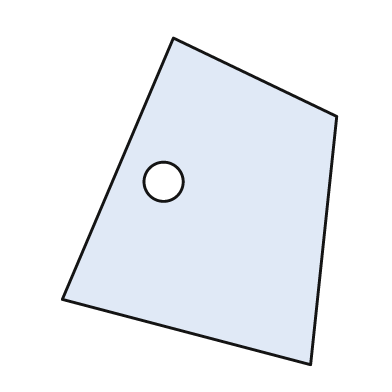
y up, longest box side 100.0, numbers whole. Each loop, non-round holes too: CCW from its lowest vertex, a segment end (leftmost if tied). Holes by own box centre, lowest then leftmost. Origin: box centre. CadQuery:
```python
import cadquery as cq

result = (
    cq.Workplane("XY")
    .moveTo(34.0, -50.0)
    .lineTo(42.0, 26.0)
    .lineTo(-8.0, 50.0)
    .lineTo(-42.0, -30.0)
    .close()
    .moveTo(-11.0, 6.0)
    .circle(6.0)
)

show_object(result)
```